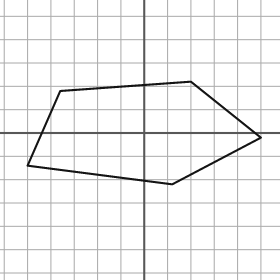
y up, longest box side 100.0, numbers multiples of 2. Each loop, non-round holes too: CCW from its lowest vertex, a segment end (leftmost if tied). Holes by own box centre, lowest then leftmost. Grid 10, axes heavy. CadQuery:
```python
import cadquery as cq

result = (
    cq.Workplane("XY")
    .moveTo(12.0, -22.0)
    .lineTo(50.0, -2.0)
    .lineTo(20.0, 22.0)
    .lineTo(-36.0, 18.0)
    .lineTo(-50.0, -14.0)
    .close()
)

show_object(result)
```